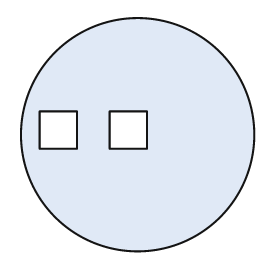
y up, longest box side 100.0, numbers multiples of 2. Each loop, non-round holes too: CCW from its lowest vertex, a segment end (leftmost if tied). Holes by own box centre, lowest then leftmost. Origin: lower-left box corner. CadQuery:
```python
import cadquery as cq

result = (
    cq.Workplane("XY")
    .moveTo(50.0, 50.0)
    .circle(50.0)
    .moveTo(8.0, 44.0)
    .lineTo(24.0, 44.0)
    .lineTo(24.0, 60.0)
    .lineTo(8.0, 60.0)
    .close()
    .moveTo(38.0, 44.0)
    .lineTo(54.0, 44.0)
    .lineTo(54.0, 60.0)
    .lineTo(38.0, 60.0)
    .close()
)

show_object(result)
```